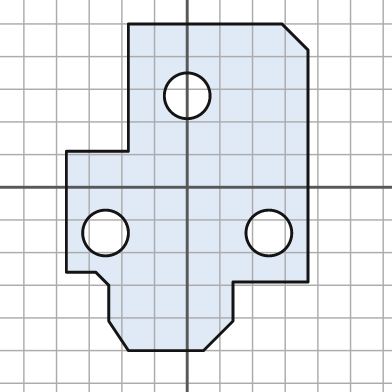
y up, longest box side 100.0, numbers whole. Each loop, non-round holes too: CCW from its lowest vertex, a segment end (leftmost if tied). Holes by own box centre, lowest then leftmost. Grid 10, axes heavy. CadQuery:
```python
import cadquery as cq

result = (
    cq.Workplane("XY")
    .moveTo(-18.0, -50.0)
    .lineTo(5.0, -50.0)
    .lineTo(14.0, -41.0)
    .lineTo(14.0, -29.0)
    .lineTo(37.0, -29.0)
    .lineTo(37.0, 42.0)
    .lineTo(29.0, 50.0)
    .lineTo(-18.0, 50.0)
    .lineTo(-18.0, 11.0)
    .lineTo(-37.0, 11.0)
    .lineTo(-37.0, -26.0)
    .lineTo(-28.0, -26.0)
    .lineTo(-24.0, -30.0)
    .lineTo(-24.0, -41.0)
    .close()
    .moveTo(-25.0, -14.0)
    .circle(7.0)
    .moveTo(25.0, -14.0)
    .circle(7.0)
    .moveTo(0.0, 28.0)
    .circle(7.0)
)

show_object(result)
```